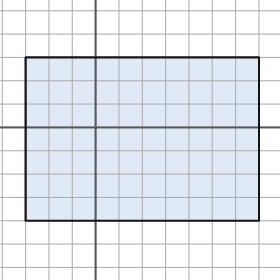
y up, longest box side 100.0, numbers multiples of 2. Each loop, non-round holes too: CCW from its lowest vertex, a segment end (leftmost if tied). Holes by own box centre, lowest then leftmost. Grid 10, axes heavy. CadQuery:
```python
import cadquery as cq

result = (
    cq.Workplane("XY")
    .moveTo(-30.0, -40.0)
    .lineTo(70.0, -40.0)
    .lineTo(70.0, 30.0)
    .lineTo(-30.0, 30.0)
    .close()
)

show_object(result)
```